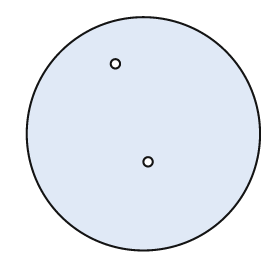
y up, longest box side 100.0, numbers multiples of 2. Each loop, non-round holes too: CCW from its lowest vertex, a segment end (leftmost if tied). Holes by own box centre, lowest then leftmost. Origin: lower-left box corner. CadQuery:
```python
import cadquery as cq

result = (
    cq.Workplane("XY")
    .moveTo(50.0, 50.0)
    .circle(50.0)
    .moveTo(52.0, 38.0)
    .circle(2.0)
    .moveTo(38.0, 80.0)
    .circle(2.0)
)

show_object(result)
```